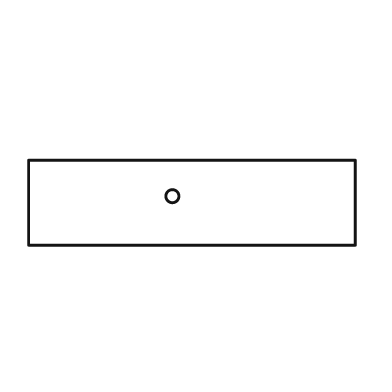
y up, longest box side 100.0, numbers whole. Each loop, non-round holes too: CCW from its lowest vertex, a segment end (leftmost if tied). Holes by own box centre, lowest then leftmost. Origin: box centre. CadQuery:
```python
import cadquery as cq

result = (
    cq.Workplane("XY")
    .moveTo(-50.0, -13.0)
    .lineTo(50.0, -13.0)
    .lineTo(50.0, 13.0)
    .lineTo(-50.0, 13.0)
    .close()
    .moveTo(-6.0, 2.0)
    .circle(2.0)
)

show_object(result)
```